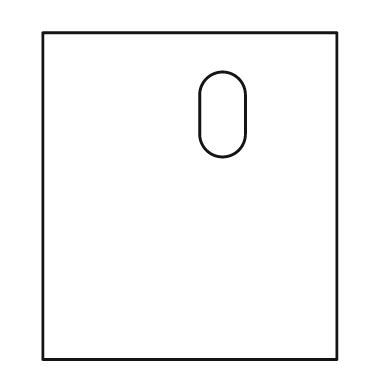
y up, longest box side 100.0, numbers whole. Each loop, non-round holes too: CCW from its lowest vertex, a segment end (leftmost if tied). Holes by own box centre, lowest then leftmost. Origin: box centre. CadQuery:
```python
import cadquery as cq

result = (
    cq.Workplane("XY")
    .moveTo(-45.0, -50.0)
    .lineTo(45.0, -50.0)
    .lineTo(45.0, 50.0)
    .lineTo(-45.0, 50.0)
    .close()
    .moveTo(3.0, 19.0)
    .threePointArc((10.0, 12.0), (17.0, 19.0))
    .lineTo(17.0, 31.0)
    .threePointArc((10.0, 38.0), (3.0, 31.0))
    .close()
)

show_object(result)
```